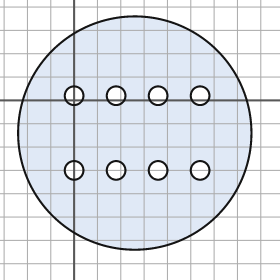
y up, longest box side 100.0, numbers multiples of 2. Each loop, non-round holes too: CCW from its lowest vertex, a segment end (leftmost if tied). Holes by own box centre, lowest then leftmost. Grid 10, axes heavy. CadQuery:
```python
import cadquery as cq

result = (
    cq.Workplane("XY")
    .moveTo(26.0, -14.0)
    .circle(50.0)
    .moveTo(0.0, -30.0)
    .circle(4.0)
    .moveTo(18.0, -30.0)
    .circle(4.0)
    .moveTo(36.0, -30.0)
    .circle(4.0)
    .moveTo(54.0, -30.0)
    .circle(4.0)
    .moveTo(0.0, 2.0)
    .circle(4.0)
    .moveTo(18.0, 2.0)
    .circle(4.0)
    .moveTo(36.0, 2.0)
    .circle(4.0)
    .moveTo(54.0, 2.0)
    .circle(4.0)
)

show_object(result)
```